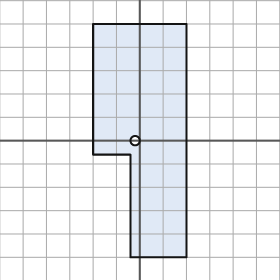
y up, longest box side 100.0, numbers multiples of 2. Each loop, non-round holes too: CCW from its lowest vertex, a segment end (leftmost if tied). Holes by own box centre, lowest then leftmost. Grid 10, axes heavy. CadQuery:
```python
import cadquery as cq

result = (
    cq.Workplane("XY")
    .moveTo(-4.0, -50.0)
    .lineTo(20.0, -50.0)
    .lineTo(20.0, 50.0)
    .lineTo(-20.0, 50.0)
    .lineTo(-20.0, -6.0)
    .lineTo(-4.0, -6.0)
    .close()
    .moveTo(-2.0, 0.0)
    .circle(2.0)
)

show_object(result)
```